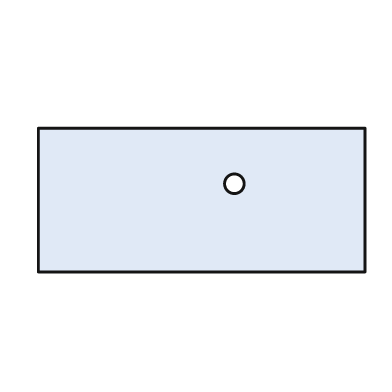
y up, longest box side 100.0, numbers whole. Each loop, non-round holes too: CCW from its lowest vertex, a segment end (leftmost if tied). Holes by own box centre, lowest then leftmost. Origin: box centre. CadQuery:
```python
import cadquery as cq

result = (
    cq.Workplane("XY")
    .moveTo(-50.0, -22.0)
    .lineTo(50.0, -22.0)
    .lineTo(50.0, 22.0)
    .lineTo(-50.0, 22.0)
    .close()
    .moveTo(10.0, 5.0)
    .circle(3.0)
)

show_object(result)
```